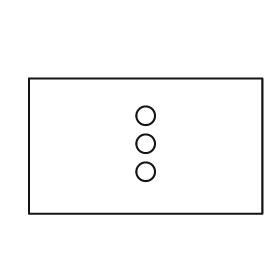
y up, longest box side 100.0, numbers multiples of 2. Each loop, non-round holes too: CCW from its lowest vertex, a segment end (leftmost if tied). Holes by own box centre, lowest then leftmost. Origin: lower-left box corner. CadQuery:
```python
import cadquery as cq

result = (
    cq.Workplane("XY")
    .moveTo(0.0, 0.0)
    .lineTo(100.0, 0.0)
    .lineTo(100.0, 58.0)
    .lineTo(0.0, 58.0)
    .close()
    .moveTo(50.0, 18.0)
    .circle(4.0)
    .moveTo(50.0, 30.0)
    .circle(4.0)
    .moveTo(50.0, 42.0)
    .circle(4.0)
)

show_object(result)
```